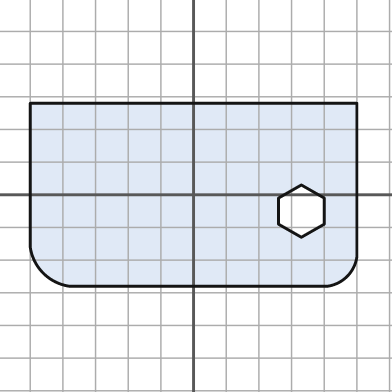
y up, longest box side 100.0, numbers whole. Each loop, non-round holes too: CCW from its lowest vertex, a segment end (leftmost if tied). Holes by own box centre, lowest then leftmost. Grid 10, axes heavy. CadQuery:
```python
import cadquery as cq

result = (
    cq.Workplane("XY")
    .moveTo(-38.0, -28.0)
    .lineTo(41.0, -28.0)
    .threePointArc((47.0, -25.0), (50.0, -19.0))
    .lineTo(50.0, 28.0)
    .lineTo(-50.0, 28.0)
    .lineTo(-50.0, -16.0)
    .threePointArc((-46.0, -24.0), (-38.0, -28.0))
    .close()
    .moveTo(33.0, -13.0)
    .lineTo(40.0, -9.0)
    .lineTo(40.0, -1.0)
    .lineTo(33.0, 3.0)
    .lineTo(26.0, -1.0)
    .lineTo(26.0, -9.0)
    .close()
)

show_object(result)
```